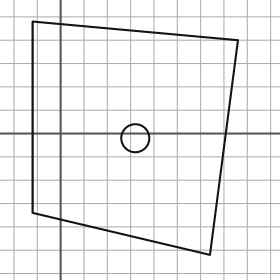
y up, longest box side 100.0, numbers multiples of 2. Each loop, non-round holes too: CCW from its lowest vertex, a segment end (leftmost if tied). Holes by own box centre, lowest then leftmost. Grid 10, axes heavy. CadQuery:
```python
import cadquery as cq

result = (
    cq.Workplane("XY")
    .moveTo(64.0, -52.0)
    .lineTo(76.0, 40.0)
    .lineTo(-12.0, 48.0)
    .lineTo(-12.0, -34.0)
    .close()
    .moveTo(32.0, -2.0)
    .circle(6.0)
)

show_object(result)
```